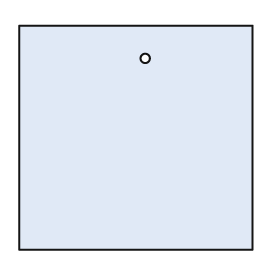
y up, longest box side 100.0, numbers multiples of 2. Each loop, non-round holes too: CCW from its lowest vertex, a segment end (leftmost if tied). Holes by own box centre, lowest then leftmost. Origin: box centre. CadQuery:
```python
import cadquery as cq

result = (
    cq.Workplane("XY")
    .moveTo(-50.0, -48.0)
    .lineTo(50.0, -48.0)
    .lineTo(50.0, 48.0)
    .lineTo(-50.0, 48.0)
    .close()
    .moveTo(4.0, 34.0)
    .circle(2.0)
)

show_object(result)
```